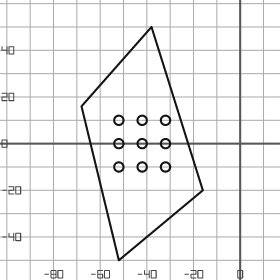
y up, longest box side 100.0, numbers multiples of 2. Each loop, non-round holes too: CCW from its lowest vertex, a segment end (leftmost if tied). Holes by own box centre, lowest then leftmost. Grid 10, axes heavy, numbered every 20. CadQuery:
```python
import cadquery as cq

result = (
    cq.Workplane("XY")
    .moveTo(-52.0, -50.0)
    .lineTo(-16.0, -20.0)
    .lineTo(-38.0, 50.0)
    .lineTo(-68.0, 16.0)
    .close()
    .moveTo(-52.0, -10.0)
    .circle(2.0)
    .moveTo(-42.0, -10.0)
    .circle(2.0)
    .moveTo(-32.0, -10.0)
    .circle(2.0)
    .moveTo(-52.0, 0.0)
    .circle(2.0)
    .moveTo(-42.0, 0.0)
    .circle(2.0)
    .moveTo(-32.0, 0.0)
    .circle(2.0)
    .moveTo(-52.0, 10.0)
    .circle(2.0)
    .moveTo(-42.0, 10.0)
    .circle(2.0)
    .moveTo(-32.0, 10.0)
    .circle(2.0)
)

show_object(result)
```